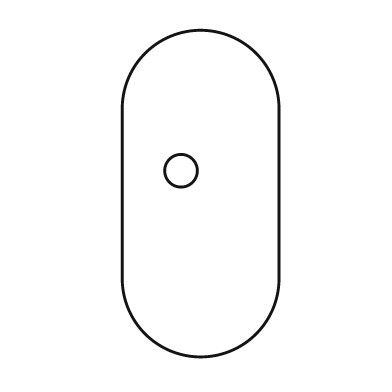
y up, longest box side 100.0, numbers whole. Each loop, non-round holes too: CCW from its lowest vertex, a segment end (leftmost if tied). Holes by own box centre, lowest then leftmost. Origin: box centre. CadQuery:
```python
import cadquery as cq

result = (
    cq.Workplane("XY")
    .moveTo(-24.0, -26.0)
    .threePointArc((0.0, -50.0), (24.0, -26.0))
    .lineTo(24.0, 26.0)
    .threePointArc((0.0, 50.0), (-24.0, 26.0))
    .close()
    .moveTo(-6.0, 7.0)
    .circle(5.0)
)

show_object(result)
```